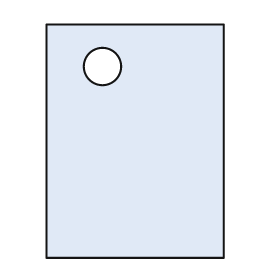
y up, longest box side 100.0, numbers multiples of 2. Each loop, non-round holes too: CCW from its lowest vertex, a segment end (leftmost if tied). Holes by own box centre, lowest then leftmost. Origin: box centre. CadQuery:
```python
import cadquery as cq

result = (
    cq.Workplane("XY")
    .moveTo(-38.0, -50.0)
    .lineTo(38.0, -50.0)
    .lineTo(38.0, 50.0)
    .lineTo(-38.0, 50.0)
    .close()
    .moveTo(-14.0, 32.0)
    .circle(8.0)
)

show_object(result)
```